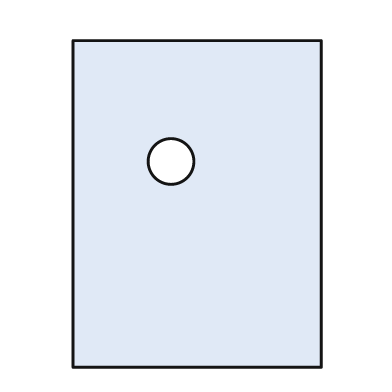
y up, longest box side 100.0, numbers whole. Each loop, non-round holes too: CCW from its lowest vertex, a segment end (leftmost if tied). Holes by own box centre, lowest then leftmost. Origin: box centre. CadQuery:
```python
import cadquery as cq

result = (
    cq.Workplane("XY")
    .moveTo(-38.0, -50.0)
    .lineTo(38.0, -50.0)
    .lineTo(38.0, 50.0)
    .lineTo(-38.0, 50.0)
    .close()
    .moveTo(-8.0, 13.0)
    .circle(7.0)
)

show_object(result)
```